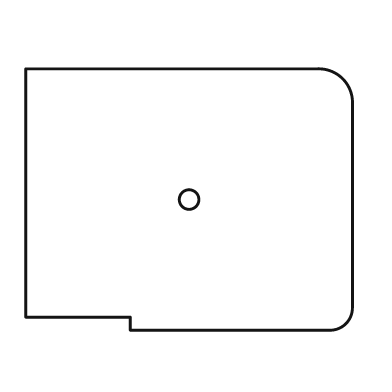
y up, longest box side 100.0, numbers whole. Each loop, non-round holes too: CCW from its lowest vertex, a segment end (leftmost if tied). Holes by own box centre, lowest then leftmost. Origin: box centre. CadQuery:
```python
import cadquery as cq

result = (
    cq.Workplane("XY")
    .moveTo(-18.0, -40.0)
    .lineTo(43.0, -40.0)
    .threePointArc((48.0, -38.0), (50.0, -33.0))
    .lineTo(50.0, 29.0)
    .threePointArc((47.0, 37.0), (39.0, 40.0))
    .lineTo(-50.0, 40.0)
    .lineTo(-50.0, -36.0)
    .lineTo(-18.0, -36.0)
    .close()
    .moveTo(0.0, 0.0)
    .circle(3.0)
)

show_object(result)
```